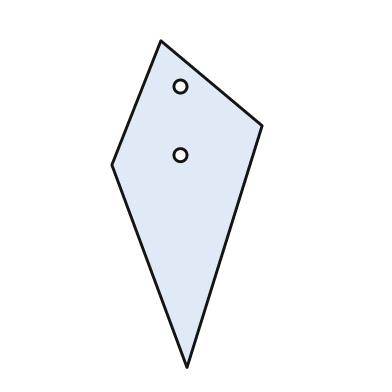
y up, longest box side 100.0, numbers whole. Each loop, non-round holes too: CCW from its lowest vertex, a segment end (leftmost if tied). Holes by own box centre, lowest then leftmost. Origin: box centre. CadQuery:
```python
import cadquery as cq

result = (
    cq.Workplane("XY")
    .moveTo(0.0, -50.0)
    .lineTo(23.0, 24.0)
    .lineTo(-8.0, 50.0)
    .lineTo(-23.0, 12.0)
    .close()
    .moveTo(-2.0, 15.0)
    .circle(2.0)
    .moveTo(-2.0, 36.0)
    .circle(2.0)
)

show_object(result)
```